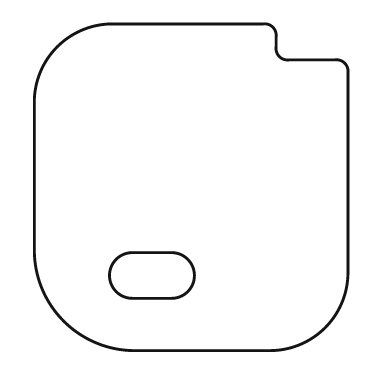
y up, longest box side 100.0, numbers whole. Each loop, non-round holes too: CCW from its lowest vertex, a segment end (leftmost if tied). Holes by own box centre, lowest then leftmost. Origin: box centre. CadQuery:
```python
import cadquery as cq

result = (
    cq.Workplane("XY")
    .moveTo(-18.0, -50.0)
    .lineTo(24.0, -50.0)
    .threePointArc((41.0, -43.0), (48.0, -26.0))
    .lineTo(48.0, 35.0)
    .threePointArc((47.0, 38.0), (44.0, 39.0))
    .lineTo(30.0, 39.0)
    .threePointArc((27.0, 40.0), (26.0, 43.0))
    .lineTo(26.0, 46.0)
    .threePointArc((25.0, 49.0), (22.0, 50.0))
    .lineTo(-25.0, 50.0)
    .threePointArc((-41.0, 43.0), (-48.0, 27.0))
    .lineTo(-48.0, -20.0)
    .threePointArc((-39.0, -41.0), (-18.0, -50.0))
    .close()
    .moveTo(-18.0, -34.0)
    .lineTo(-6.0, -34.0)
    .threePointArc((1.0, -27.0), (-6.0, -20.0))
    .lineTo(-18.0, -20.0)
    .threePointArc((-25.0, -27.0), (-18.0, -34.0))
    .close()
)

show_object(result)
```